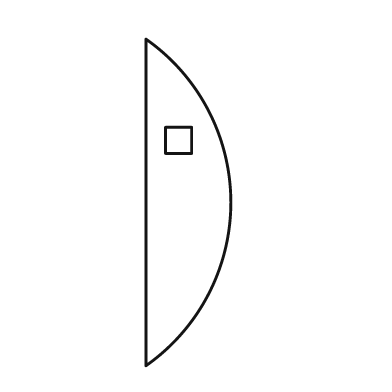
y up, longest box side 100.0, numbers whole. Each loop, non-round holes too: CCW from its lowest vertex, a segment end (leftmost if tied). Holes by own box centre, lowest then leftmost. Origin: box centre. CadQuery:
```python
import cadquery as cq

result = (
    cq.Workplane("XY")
    .moveTo(-13.0, -50.0)
    .threePointArc((13.0, 0.0), (-13.0, 50.0))
    .close()
    .moveTo(-7.0, 15.0)
    .lineTo(1.0, 15.0)
    .lineTo(1.0, 23.0)
    .lineTo(-7.0, 23.0)
    .close()
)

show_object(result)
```